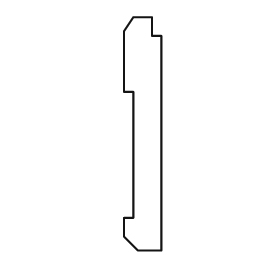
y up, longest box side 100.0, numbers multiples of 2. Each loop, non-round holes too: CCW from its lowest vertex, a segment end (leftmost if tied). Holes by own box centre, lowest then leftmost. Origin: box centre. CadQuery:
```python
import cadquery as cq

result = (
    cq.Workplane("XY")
    .moveTo(-2.0, -50.0)
    .lineTo(8.0, -50.0)
    .lineTo(8.0, 42.0)
    .lineTo(4.0, 42.0)
    .lineTo(4.0, 50.0)
    .lineTo(-4.0, 50.0)
    .lineTo(-8.0, 44.0)
    .lineTo(-8.0, 18.0)
    .lineTo(-4.0, 18.0)
    .lineTo(-4.0, -36.0)
    .lineTo(-8.0, -36.0)
    .lineTo(-8.0, -44.0)
    .close()
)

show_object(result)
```